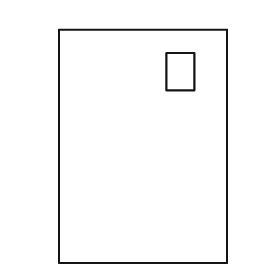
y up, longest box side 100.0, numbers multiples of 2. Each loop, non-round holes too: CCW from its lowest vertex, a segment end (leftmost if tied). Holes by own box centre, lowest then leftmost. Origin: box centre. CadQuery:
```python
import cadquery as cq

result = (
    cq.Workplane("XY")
    .moveTo(-36.0, -50.0)
    .lineTo(36.0, -50.0)
    .lineTo(36.0, 50.0)
    .lineTo(-36.0, 50.0)
    .close()
    .moveTo(10.0, 24.0)
    .lineTo(22.0, 24.0)
    .lineTo(22.0, 40.0)
    .lineTo(10.0, 40.0)
    .close()
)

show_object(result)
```